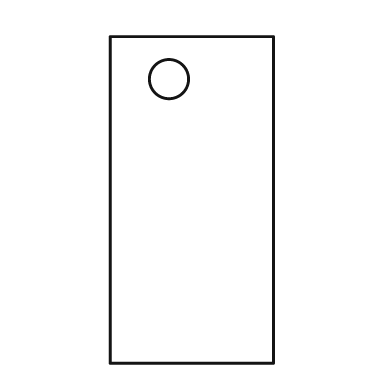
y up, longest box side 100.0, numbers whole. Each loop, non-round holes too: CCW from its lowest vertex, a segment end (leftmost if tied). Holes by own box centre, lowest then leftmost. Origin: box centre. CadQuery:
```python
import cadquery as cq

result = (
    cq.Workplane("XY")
    .moveTo(-25.0, -50.0)
    .lineTo(25.0, -50.0)
    .lineTo(25.0, 50.0)
    .lineTo(-25.0, 50.0)
    .close()
    .moveTo(-7.0, 37.0)
    .circle(6.0)
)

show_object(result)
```